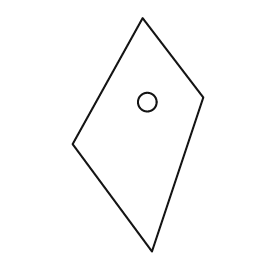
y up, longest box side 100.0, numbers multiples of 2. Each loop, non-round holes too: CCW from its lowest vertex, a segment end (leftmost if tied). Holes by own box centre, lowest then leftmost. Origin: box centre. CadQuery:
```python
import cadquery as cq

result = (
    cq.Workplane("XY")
    .moveTo(6.0, -50.0)
    .lineTo(28.0, 16.0)
    .lineTo(2.0, 50.0)
    .lineTo(-28.0, -4.0)
    .close()
    .moveTo(4.0, 14.0)
    .circle(4.0)
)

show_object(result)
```